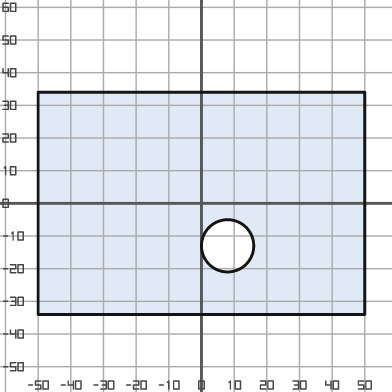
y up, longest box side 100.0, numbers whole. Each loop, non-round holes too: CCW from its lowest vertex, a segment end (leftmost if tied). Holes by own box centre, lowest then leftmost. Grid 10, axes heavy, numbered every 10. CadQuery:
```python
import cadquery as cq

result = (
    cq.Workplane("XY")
    .moveTo(-50.0, -34.0)
    .lineTo(50.0, -34.0)
    .lineTo(50.0, 34.0)
    .lineTo(-50.0, 34.0)
    .close()
    .moveTo(8.0, -13.0)
    .circle(8.0)
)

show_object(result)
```